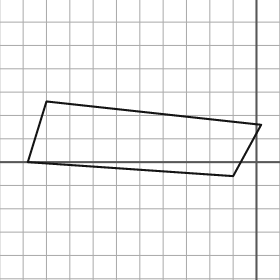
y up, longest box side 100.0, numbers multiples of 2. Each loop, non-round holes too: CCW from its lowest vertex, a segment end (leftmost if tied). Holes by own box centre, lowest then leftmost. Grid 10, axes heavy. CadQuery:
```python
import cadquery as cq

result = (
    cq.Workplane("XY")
    .moveTo(-10.0, -6.0)
    .lineTo(2.0, 16.0)
    .lineTo(-90.0, 26.0)
    .lineTo(-98.0, 0.0)
    .close()
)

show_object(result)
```